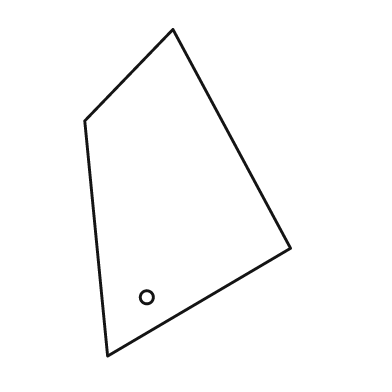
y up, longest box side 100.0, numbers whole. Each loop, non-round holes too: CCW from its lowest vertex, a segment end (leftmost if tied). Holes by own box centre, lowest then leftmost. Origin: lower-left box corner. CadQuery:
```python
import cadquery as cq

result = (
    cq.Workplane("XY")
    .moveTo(7.0, 0.0)
    .lineTo(63.0, 33.0)
    .lineTo(27.0, 100.0)
    .lineTo(0.0, 72.0)
    .close()
    .moveTo(19.0, 18.0)
    .circle(2.0)
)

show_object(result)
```